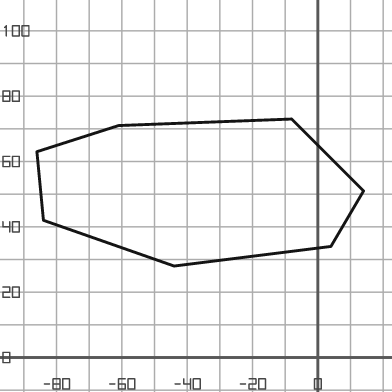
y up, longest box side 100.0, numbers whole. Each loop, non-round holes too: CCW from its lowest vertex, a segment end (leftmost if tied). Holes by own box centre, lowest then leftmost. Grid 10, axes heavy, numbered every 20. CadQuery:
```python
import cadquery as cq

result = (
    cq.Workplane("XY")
    .moveTo(-44.0, 28.0)
    .lineTo(4.0, 34.0)
    .lineTo(14.0, 51.0)
    .lineTo(-8.0, 73.0)
    .lineTo(-61.0, 71.0)
    .lineTo(-86.0, 63.0)
    .lineTo(-84.0, 42.0)
    .close()
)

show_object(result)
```